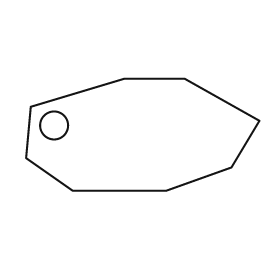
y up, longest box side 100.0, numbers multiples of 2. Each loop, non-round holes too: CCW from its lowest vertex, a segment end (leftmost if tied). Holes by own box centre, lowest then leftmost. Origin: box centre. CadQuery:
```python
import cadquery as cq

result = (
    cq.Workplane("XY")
    .moveTo(-30.0, -24.0)
    .lineTo(10.0, -24.0)
    .lineTo(38.0, -14.0)
    .lineTo(50.0, 6.0)
    .lineTo(18.0, 24.0)
    .lineTo(-8.0, 24.0)
    .lineTo(-48.0, 12.0)
    .lineTo(-50.0, -10.0)
    .close()
    .moveTo(-38.0, 4.0)
    .circle(6.0)
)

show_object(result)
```